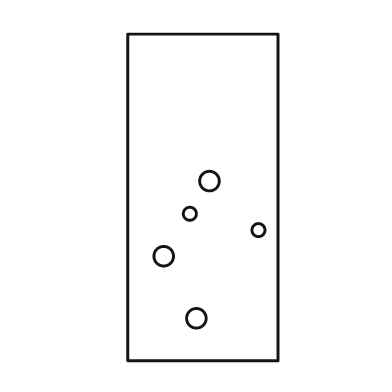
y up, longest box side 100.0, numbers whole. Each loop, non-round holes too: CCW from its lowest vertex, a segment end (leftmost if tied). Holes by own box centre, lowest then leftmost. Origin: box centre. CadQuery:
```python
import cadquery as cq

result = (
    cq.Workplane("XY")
    .moveTo(-23.0, -50.0)
    .lineTo(23.0, -50.0)
    .lineTo(23.0, 50.0)
    .lineTo(-23.0, 50.0)
    .close()
    .moveTo(-2.0, -37.0)
    .circle(3.0)
    .moveTo(-12.0, -18.0)
    .circle(3.0)
    .moveTo(17.0, -10.0)
    .circle(2.0)
    .moveTo(-4.0, -5.0)
    .circle(2.0)
    .moveTo(2.0, 5.0)
    .circle(3.0)
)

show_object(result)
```